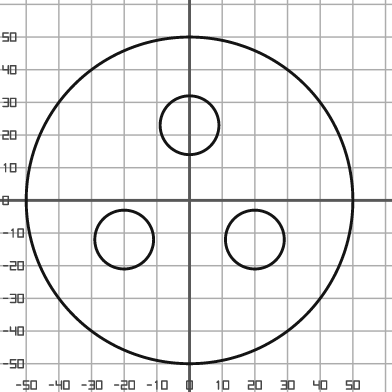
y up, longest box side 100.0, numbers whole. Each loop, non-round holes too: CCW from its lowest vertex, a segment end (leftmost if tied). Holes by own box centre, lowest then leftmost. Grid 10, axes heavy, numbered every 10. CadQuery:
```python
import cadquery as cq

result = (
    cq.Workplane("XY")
    .moveTo(0.0, 0.0)
    .circle(50.0)
    .moveTo(-20.0, -12.0)
    .circle(9.0)
    .moveTo(20.0, -12.0)
    .circle(9.0)
    .moveTo(0.0, 23.0)
    .circle(9.0)
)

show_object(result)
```